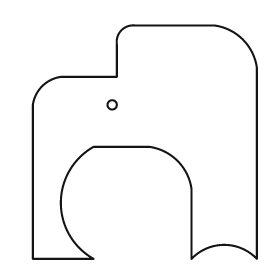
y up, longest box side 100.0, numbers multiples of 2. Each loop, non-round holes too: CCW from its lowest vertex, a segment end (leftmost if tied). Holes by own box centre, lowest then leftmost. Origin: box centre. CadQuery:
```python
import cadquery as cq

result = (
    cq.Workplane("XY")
    .moveTo(-48.0, -50.0)
    .lineTo(-22.0, -50.0)
    .threePointArc((-36.0, -26.0), (-22.0, -2.0))
    .lineTo(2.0, -2.0)
    .threePointArc((14.0, -8.0), (20.0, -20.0))
    .lineTo(20.0, -50.0)
    .threePointArc((34.0, -44.0), (48.0, -50.0))
    .lineTo(48.0, 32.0)
    .threePointArc((42.0, 44.0), (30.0, 50.0))
    .lineTo(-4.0, 50.0)
    .threePointArc((-10.0, 48.0), (-12.0, 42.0))
    .lineTo(-12.0, 28.0)
    .lineTo(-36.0, 28.0)
    .threePointArc((-44.0, 24.0), (-48.0, 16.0))
    .close()
    .moveTo(-14.0, 16.0)
    .circle(2.0)
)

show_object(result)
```